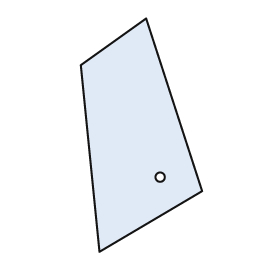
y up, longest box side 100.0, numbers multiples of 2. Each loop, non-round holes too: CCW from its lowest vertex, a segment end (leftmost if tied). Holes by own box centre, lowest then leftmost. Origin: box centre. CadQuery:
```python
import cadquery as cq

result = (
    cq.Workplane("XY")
    .moveTo(-18.0, -50.0)
    .lineTo(26.0, -24.0)
    .lineTo(2.0, 50.0)
    .lineTo(-26.0, 30.0)
    .close()
    .moveTo(8.0, -18.0)
    .circle(2.0)
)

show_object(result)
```